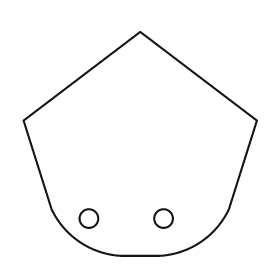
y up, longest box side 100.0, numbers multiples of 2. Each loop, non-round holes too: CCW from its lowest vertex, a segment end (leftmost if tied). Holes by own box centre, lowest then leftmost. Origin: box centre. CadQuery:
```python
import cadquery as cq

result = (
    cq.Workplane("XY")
    .moveTo(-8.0, -48.0)
    .lineTo(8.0, -48.0)
    .threePointArc((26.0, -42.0), (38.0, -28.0))
    .lineTo(50.0, 10.0)
    .lineTo(0.0, 48.0)
    .lineTo(-50.0, 10.0)
    .lineTo(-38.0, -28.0)
    .threePointArc((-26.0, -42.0), (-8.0, -48.0))
    .close()
    .moveTo(-22.0, -32.0)
    .circle(4.0)
    .moveTo(10.0, -32.0)
    .circle(4.0)
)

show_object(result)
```